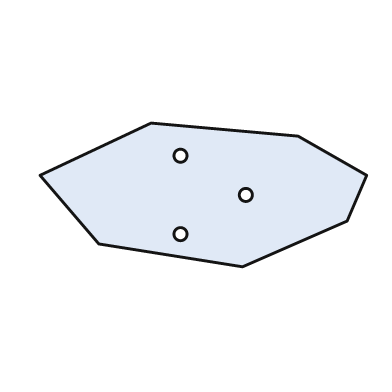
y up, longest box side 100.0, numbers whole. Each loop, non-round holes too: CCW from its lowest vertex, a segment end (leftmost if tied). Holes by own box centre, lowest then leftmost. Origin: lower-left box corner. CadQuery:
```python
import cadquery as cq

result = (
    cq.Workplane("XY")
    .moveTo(62.0, 0.0)
    .lineTo(94.0, 14.0)
    .lineTo(100.0, 28.0)
    .lineTo(79.0, 40.0)
    .lineTo(34.0, 44.0)
    .lineTo(0.0, 28.0)
    .lineTo(18.0, 7.0)
    .close()
    .moveTo(43.0, 10.0)
    .circle(2.0)
    .moveTo(63.0, 22.0)
    .circle(2.0)
    .moveTo(43.0, 34.0)
    .circle(2.0)
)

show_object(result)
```